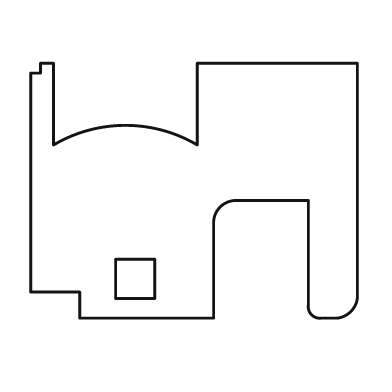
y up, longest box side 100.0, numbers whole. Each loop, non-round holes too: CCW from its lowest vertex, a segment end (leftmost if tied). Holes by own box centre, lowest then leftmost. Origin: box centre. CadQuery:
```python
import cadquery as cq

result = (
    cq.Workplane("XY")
    .moveTo(-35.0, -39.0)
    .lineTo(6.0, -39.0)
    .lineTo(6.0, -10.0)
    .threePointArc((8.0, -5.0), (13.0, -3.0))
    .lineTo(35.0, -3.0)
    .lineTo(35.0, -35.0)
    .threePointArc((36.0, -38.0), (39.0, -39.0))
    .lineTo(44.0, -39.0)
    .threePointArc((48.0, -37.0), (50.0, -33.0))
    .lineTo(50.0, 39.0)
    .lineTo(1.0, 39.0)
    .lineTo(1.0, 14.0)
    .threePointArc((-21.0, 20.0), (-43.0, 14.0))
    .lineTo(-43.0, 39.0)
    .lineTo(-47.0, 39.0)
    .lineTo(-47.0, 36.0)
    .lineTo(-50.0, 36.0)
    .lineTo(-50.0, -31.0)
    .lineTo(-35.0, -31.0)
    .close()
    .moveTo(-24.0, -33.0)
    .lineTo(-12.0, -33.0)
    .lineTo(-12.0, -21.0)
    .lineTo(-24.0, -21.0)
    .close()
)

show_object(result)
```